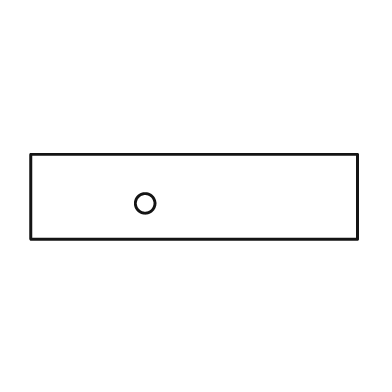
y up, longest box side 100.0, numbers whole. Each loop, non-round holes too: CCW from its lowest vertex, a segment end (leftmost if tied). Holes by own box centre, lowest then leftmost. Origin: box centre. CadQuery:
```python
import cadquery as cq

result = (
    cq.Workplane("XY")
    .moveTo(-50.0, -13.0)
    .lineTo(50.0, -13.0)
    .lineTo(50.0, 13.0)
    .lineTo(-50.0, 13.0)
    .close()
    .moveTo(-15.0, -2.0)
    .circle(3.0)
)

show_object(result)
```